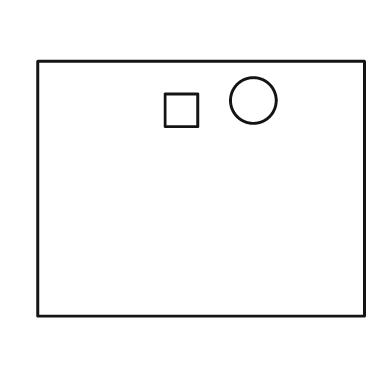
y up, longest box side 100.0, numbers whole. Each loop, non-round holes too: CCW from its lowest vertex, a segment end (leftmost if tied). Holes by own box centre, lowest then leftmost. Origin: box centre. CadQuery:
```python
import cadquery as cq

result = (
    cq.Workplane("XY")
    .moveTo(-50.0, -39.0)
    .lineTo(50.0, -39.0)
    .lineTo(50.0, 39.0)
    .lineTo(-50.0, 39.0)
    .close()
    .moveTo(-11.0, 19.0)
    .lineTo(-1.0, 19.0)
    .lineTo(-1.0, 29.0)
    .lineTo(-11.0, 29.0)
    .close()
    .moveTo(16.0, 27.0)
    .circle(7.0)
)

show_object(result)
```